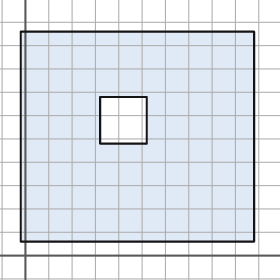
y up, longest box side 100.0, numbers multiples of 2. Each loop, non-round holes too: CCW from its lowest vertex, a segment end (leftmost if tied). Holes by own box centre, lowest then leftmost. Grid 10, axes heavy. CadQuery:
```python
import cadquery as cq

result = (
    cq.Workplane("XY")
    .moveTo(-2.0, 6.0)
    .lineTo(98.0, 6.0)
    .lineTo(98.0, 96.0)
    .lineTo(-2.0, 96.0)
    .close()
    .moveTo(32.0, 48.0)
    .lineTo(52.0, 48.0)
    .lineTo(52.0, 68.0)
    .lineTo(32.0, 68.0)
    .close()
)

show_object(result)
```